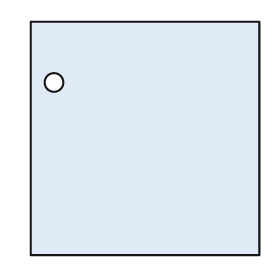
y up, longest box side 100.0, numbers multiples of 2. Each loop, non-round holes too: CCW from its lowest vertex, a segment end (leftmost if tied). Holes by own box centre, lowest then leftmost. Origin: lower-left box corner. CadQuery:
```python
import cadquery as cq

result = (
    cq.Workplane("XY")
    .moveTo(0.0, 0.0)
    .lineTo(98.0, 0.0)
    .lineTo(98.0, 100.0)
    .lineTo(0.0, 100.0)
    .close()
    .moveTo(10.0, 74.0)
    .circle(4.0)
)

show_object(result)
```